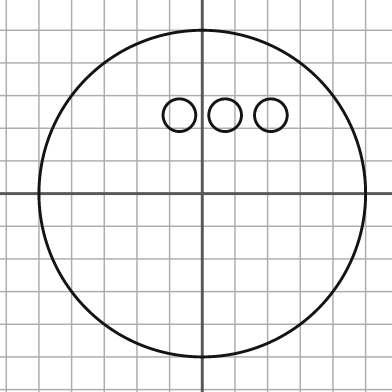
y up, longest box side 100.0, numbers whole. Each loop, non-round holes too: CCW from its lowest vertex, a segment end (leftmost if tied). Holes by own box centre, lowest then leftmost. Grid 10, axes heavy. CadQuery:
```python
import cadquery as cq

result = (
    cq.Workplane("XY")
    .moveTo(0.0, 0.0)
    .circle(50.0)
    .moveTo(-7.0, 24.0)
    .circle(5.0)
    .moveTo(7.0, 24.0)
    .circle(5.0)
    .moveTo(21.0, 24.0)
    .circle(5.0)
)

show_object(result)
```